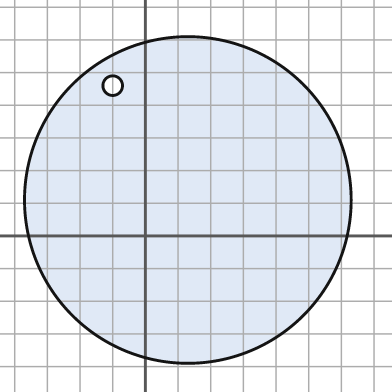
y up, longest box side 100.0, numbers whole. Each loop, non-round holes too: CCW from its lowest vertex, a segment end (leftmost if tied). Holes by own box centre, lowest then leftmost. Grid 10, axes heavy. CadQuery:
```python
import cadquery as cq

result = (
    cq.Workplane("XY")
    .moveTo(13.0, 11.0)
    .circle(50.0)
    .moveTo(-10.0, 46.0)
    .circle(3.0)
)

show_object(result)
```